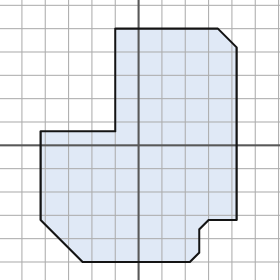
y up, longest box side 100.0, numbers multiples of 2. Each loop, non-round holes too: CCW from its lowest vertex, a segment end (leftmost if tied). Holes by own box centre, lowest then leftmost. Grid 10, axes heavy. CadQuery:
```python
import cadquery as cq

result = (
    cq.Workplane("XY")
    .moveTo(-24.0, -50.0)
    .lineTo(22.0, -50.0)
    .lineTo(26.0, -46.0)
    .lineTo(26.0, -36.0)
    .lineTo(30.0, -32.0)
    .lineTo(42.0, -32.0)
    .lineTo(42.0, 42.0)
    .lineTo(34.0, 50.0)
    .lineTo(-10.0, 50.0)
    .lineTo(-10.0, 6.0)
    .lineTo(-42.0, 6.0)
    .lineTo(-42.0, -32.0)
    .close()
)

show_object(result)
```